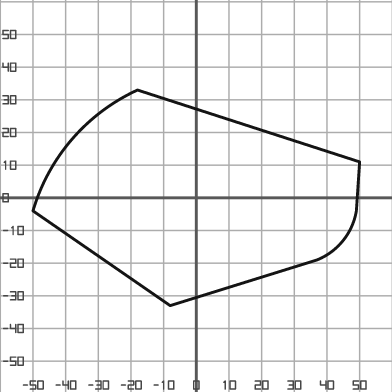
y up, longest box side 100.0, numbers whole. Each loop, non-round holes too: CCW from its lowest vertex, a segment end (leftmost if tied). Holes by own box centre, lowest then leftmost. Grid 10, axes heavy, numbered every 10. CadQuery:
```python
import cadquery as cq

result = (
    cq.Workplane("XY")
    .moveTo(-8.0, -33.0)
    .lineTo(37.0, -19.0)
    .threePointArc((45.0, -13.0), (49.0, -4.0))
    .lineTo(50.0, 11.0)
    .lineTo(-18.0, 33.0)
    .threePointArc((-38.0, 18.0), (-50.0, -4.0))
    .close()
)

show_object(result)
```